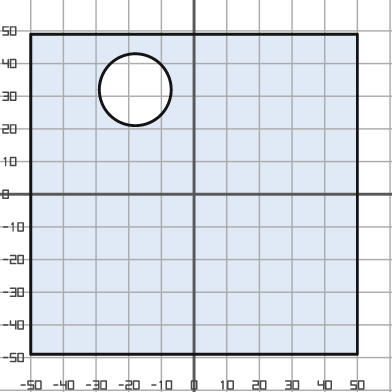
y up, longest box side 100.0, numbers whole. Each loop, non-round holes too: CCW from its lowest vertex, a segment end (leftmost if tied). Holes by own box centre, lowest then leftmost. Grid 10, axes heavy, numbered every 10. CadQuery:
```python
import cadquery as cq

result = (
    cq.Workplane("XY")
    .moveTo(-50.0, -49.0)
    .lineTo(50.0, -49.0)
    .lineTo(50.0, 49.0)
    .lineTo(-50.0, 49.0)
    .close()
    .moveTo(-18.0, 32.0)
    .circle(11.0)
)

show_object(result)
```